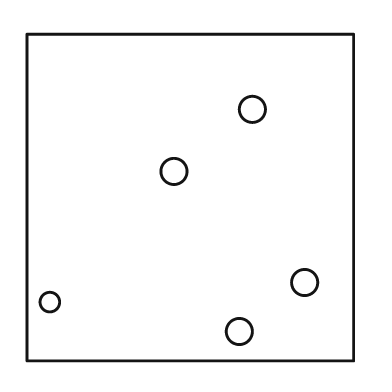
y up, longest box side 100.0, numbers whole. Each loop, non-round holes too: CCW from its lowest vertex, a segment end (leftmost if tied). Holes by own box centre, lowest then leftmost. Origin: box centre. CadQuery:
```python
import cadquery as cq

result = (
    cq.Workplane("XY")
    .moveTo(-50.0, -50.0)
    .lineTo(50.0, -50.0)
    .lineTo(50.0, 50.0)
    .lineTo(-50.0, 50.0)
    .close()
    .moveTo(15.0, -41.0)
    .circle(4.0)
    .moveTo(-43.0, -32.0)
    .circle(3.0)
    .moveTo(35.0, -26.0)
    .circle(4.0)
    .moveTo(-5.0, 8.0)
    .circle(4.0)
    .moveTo(19.0, 27.0)
    .circle(4.0)
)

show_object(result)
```